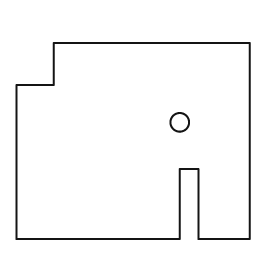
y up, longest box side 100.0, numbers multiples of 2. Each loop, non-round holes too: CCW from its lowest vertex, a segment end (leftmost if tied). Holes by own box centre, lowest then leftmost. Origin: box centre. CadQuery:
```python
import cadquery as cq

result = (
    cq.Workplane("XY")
    .moveTo(-50.0, -42.0)
    .lineTo(20.0, -42.0)
    .lineTo(20.0, -12.0)
    .lineTo(28.0, -12.0)
    .lineTo(28.0, -42.0)
    .lineTo(50.0, -42.0)
    .lineTo(50.0, 42.0)
    .lineTo(-34.0, 42.0)
    .lineTo(-34.0, 24.0)
    .lineTo(-50.0, 24.0)
    .close()
    .moveTo(20.0, 8.0)
    .circle(4.0)
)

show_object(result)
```